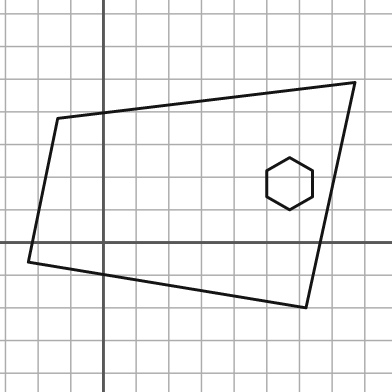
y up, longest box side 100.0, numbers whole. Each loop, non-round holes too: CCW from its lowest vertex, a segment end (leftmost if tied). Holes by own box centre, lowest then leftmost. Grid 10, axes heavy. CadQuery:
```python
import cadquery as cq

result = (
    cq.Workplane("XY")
    .moveTo(62.0, -20.0)
    .lineTo(77.0, 49.0)
    .lineTo(-14.0, 38.0)
    .lineTo(-23.0, -6.0)
    .close()
    .moveTo(57.0, 10.0)
    .lineTo(64.0, 14.0)
    .lineTo(64.0, 22.0)
    .lineTo(57.0, 26.0)
    .lineTo(50.0, 22.0)
    .lineTo(50.0, 14.0)
    .close()
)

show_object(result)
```